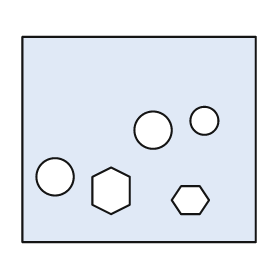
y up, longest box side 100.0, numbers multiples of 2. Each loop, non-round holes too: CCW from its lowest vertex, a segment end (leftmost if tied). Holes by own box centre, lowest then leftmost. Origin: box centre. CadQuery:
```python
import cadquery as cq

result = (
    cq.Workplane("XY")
    .moveTo(-50.0, -44.0)
    .lineTo(50.0, -44.0)
    .lineTo(50.0, 44.0)
    .lineTo(-50.0, 44.0)
    .close()
    .moveTo(18.0, -32.0)
    .lineTo(26.0, -32.0)
    .lineTo(30.0, -26.0)
    .lineTo(26.0, -20.0)
    .lineTo(18.0, -20.0)
    .lineTo(14.0, -26.0)
    .close()
    .moveTo(-12.0, -32.0)
    .lineTo(-4.0, -28.0)
    .lineTo(-4.0, -16.0)
    .lineTo(-12.0, -12.0)
    .lineTo(-20.0, -16.0)
    .lineTo(-20.0, -28.0)
    .close()
    .moveTo(-36.0, -16.0)
    .circle(8.0)
    .moveTo(6.0, 4.0)
    .circle(8.0)
    .moveTo(28.0, 8.0)
    .circle(6.0)
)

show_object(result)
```